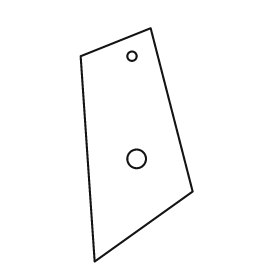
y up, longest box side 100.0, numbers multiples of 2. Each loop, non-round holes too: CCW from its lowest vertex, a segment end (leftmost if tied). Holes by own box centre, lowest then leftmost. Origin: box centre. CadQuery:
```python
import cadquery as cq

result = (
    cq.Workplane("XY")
    .moveTo(-18.0, -50.0)
    .lineTo(24.0, -20.0)
    .lineTo(6.0, 50.0)
    .lineTo(-24.0, 38.0)
    .close()
    .moveTo(0.0, -6.0)
    .circle(4.0)
    .moveTo(-2.0, 38.0)
    .circle(2.0)
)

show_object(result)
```